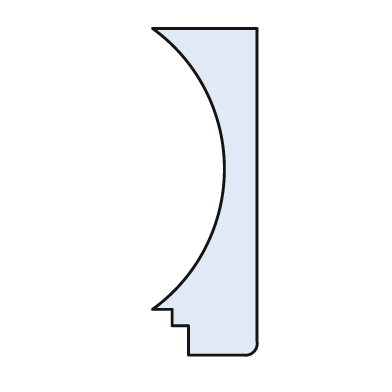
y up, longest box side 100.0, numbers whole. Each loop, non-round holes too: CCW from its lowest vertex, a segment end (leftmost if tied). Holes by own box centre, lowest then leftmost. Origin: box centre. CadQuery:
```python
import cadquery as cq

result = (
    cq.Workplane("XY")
    .moveTo(-5.0, -50.0)
    .lineTo(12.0, -50.0)
    .threePointArc((15.0, -49.0), (16.0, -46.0))
    .lineTo(16.0, 50.0)
    .lineTo(-16.0, 50.0)
    .threePointArc((6.0, 7.0), (-16.0, -36.0))
    .lineTo(-10.0, -36.0)
    .lineTo(-10.0, -41.0)
    .lineTo(-5.0, -41.0)
    .close()
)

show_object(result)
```